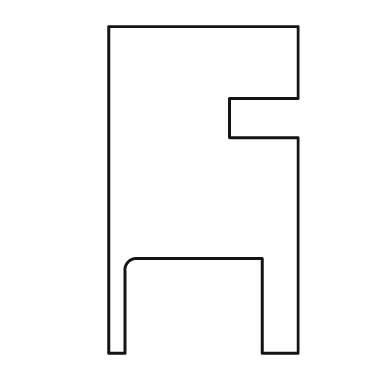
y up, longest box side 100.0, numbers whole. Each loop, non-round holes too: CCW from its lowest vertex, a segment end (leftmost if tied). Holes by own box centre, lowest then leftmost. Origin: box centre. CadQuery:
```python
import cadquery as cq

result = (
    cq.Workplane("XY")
    .moveTo(-29.0, -50.0)
    .lineTo(-24.0, -50.0)
    .lineTo(-24.0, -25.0)
    .threePointArc((-23.0, -22.0), (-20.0, -21.0))
    .lineTo(18.0, -21.0)
    .lineTo(18.0, -50.0)
    .lineTo(29.0, -50.0)
    .lineTo(29.0, 16.0)
    .lineTo(8.0, 16.0)
    .lineTo(8.0, 28.0)
    .lineTo(29.0, 28.0)
    .lineTo(29.0, 50.0)
    .lineTo(-29.0, 50.0)
    .close()
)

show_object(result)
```